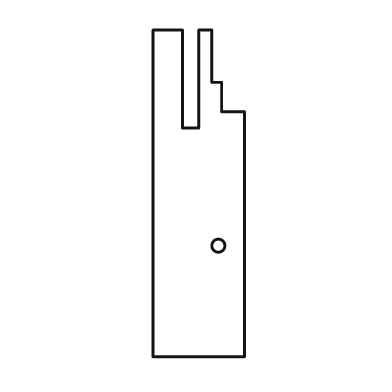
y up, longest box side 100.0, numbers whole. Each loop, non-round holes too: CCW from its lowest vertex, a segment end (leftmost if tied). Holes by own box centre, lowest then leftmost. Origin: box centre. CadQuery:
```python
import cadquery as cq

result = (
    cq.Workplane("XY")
    .moveTo(-14.0, -50.0)
    .lineTo(14.0, -50.0)
    .lineTo(14.0, 25.0)
    .lineTo(7.0, 25.0)
    .lineTo(7.0, 34.0)
    .lineTo(4.0, 34.0)
    .lineTo(4.0, 50.0)
    .lineTo(0.0, 50.0)
    .lineTo(0.0, 20.0)
    .lineTo(-5.0, 20.0)
    .lineTo(-5.0, 50.0)
    .lineTo(-14.0, 50.0)
    .close()
    .moveTo(6.0, -16.0)
    .circle(2.0)
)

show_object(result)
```